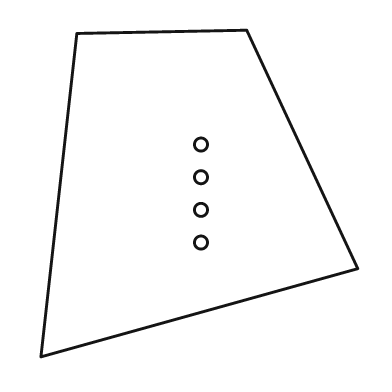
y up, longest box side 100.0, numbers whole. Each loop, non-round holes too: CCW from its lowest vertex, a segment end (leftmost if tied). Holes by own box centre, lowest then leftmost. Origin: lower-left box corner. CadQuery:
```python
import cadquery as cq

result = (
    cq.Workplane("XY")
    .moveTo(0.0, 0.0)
    .lineTo(97.0, 27.0)
    .lineTo(63.0, 100.0)
    .lineTo(11.0, 99.0)
    .close()
    .moveTo(49.0, 35.0)
    .circle(2.0)
    .moveTo(49.0, 45.0)
    .circle(2.0)
    .moveTo(49.0, 55.0)
    .circle(2.0)
    .moveTo(49.0, 65.0)
    .circle(2.0)
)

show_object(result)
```